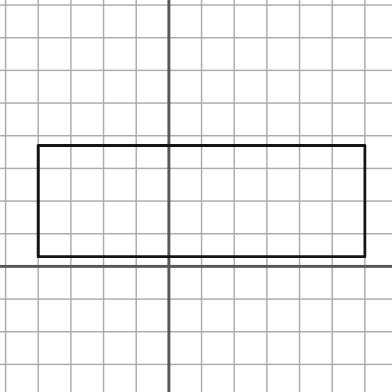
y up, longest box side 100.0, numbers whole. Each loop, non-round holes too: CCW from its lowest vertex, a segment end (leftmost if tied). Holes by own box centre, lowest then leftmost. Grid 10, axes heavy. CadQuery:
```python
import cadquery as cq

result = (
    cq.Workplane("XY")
    .moveTo(-40.0, 3.0)
    .lineTo(60.0, 3.0)
    .lineTo(60.0, 37.0)
    .lineTo(-40.0, 37.0)
    .close()
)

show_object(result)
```